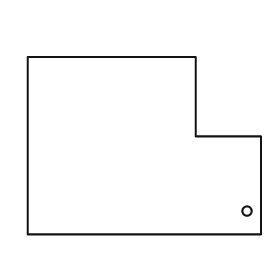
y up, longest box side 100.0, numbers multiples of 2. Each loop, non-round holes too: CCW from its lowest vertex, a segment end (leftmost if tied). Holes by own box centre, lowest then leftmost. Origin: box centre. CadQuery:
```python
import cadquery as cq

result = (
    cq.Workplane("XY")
    .moveTo(-50.0, -38.0)
    .lineTo(50.0, -38.0)
    .lineTo(50.0, 4.0)
    .lineTo(22.0, 4.0)
    .lineTo(22.0, 38.0)
    .lineTo(-50.0, 38.0)
    .close()
    .moveTo(44.0, -28.0)
    .circle(2.0)
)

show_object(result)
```